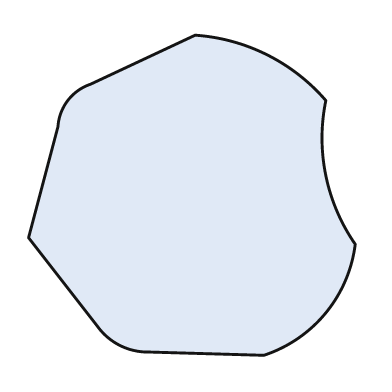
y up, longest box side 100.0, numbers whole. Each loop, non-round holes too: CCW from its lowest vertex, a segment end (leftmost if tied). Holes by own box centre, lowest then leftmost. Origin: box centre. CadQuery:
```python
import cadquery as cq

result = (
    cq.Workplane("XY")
    .moveTo(22.0, -49.0)
    .threePointArc((41.0, -36.0), (50.0, -15.0))
    .threePointArc((41.0, 6.0), (41.0, 29.0))
    .threePointArc((23.0, 43.0), (1.0, 49.0))
    .lineTo(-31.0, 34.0)
    .threePointArc((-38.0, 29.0), (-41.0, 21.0))
    .lineTo(-50.0, -13.0)
    .lineTo(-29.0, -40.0)
    .threePointArc((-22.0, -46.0), (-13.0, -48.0))
    .close()
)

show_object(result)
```